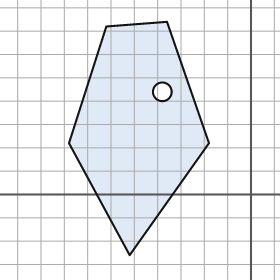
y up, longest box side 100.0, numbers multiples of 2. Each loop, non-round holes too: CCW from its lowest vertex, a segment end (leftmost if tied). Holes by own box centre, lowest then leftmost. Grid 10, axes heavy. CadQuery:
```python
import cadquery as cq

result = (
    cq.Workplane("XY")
    .moveTo(-52.0, -26.0)
    .lineTo(-18.0, 22.0)
    .lineTo(-36.0, 74.0)
    .lineTo(-62.0, 72.0)
    .lineTo(-78.0, 22.0)
    .close()
    .moveTo(-38.0, 44.0)
    .circle(4.0)
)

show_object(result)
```